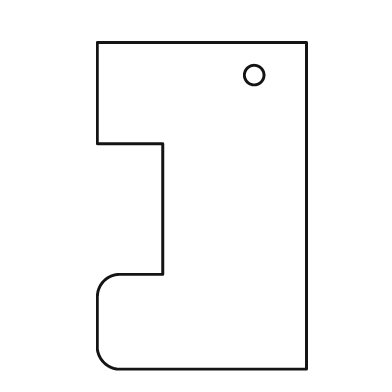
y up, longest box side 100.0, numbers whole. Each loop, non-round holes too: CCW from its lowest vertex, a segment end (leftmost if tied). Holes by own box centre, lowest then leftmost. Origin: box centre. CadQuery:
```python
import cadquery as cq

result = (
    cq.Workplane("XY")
    .moveTo(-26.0, -50.0)
    .lineTo(32.0, -50.0)
    .lineTo(32.0, 50.0)
    .lineTo(-32.0, 50.0)
    .lineTo(-32.0, 19.0)
    .lineTo(-12.0, 19.0)
    .lineTo(-12.0, -21.0)
    .lineTo(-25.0, -21.0)
    .threePointArc((-30.0, -23.0), (-32.0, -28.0))
    .lineTo(-32.0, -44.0)
    .threePointArc((-30.0, -48.0), (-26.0, -50.0))
    .close()
    .moveTo(16.0, 40.0)
    .circle(3.0)
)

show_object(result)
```